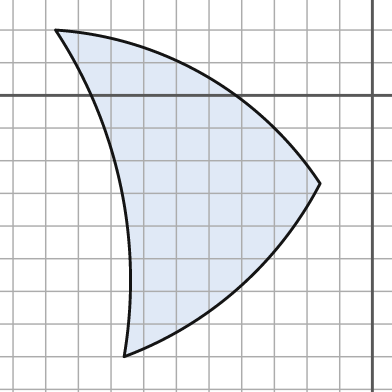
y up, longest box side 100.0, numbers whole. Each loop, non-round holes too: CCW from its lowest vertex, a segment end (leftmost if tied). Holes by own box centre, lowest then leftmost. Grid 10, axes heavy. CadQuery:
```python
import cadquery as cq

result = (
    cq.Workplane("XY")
    .moveTo(-76.0, -80.0)
    .threePointArc((-41.0, -59.0), (-16.0, -27.0))
    .threePointArc((-51.0, 6.0), (-97.0, 20.0))
    .threePointArc((-77.0, -28.0), (-76.0, -80.0))
    .close()
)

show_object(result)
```